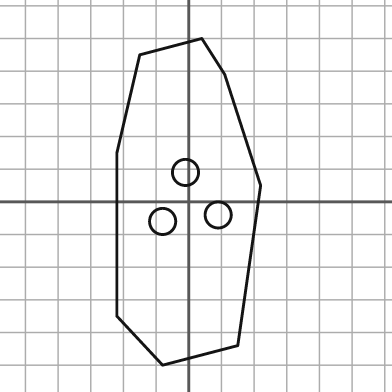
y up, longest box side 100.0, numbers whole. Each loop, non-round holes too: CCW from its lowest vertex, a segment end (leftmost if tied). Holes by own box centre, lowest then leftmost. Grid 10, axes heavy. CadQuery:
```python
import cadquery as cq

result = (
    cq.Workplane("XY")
    .moveTo(-8.0, -50.0)
    .lineTo(15.0, -44.0)
    .lineTo(22.0, 5.0)
    .lineTo(11.0, 39.0)
    .lineTo(4.0, 50.0)
    .lineTo(-15.0, 45.0)
    .lineTo(-22.0, 15.0)
    .lineTo(-22.0, -35.0)
    .close()
    .moveTo(-8.0, -6.0)
    .circle(4.0)
    .moveTo(9.0, -4.0)
    .circle(4.0)
    .moveTo(-1.0, 9.0)
    .circle(4.0)
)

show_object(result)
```